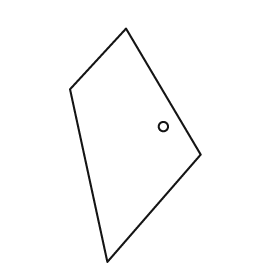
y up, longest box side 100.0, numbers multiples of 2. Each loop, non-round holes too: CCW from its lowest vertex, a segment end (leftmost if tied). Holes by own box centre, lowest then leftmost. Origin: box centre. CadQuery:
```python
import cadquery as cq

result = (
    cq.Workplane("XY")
    .moveTo(-12.0, -50.0)
    .lineTo(28.0, -4.0)
    .lineTo(-4.0, 50.0)
    .lineTo(-28.0, 24.0)
    .close()
    .moveTo(12.0, 8.0)
    .circle(2.0)
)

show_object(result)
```